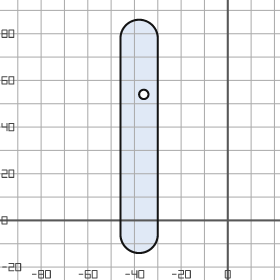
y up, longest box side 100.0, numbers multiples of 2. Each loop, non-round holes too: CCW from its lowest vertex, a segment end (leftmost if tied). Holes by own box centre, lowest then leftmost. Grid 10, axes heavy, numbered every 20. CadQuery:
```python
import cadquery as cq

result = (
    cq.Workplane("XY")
    .moveTo(-46.0, -6.0)
    .threePointArc((-38.0, -14.0), (-30.0, -6.0))
    .lineTo(-30.0, 78.0)
    .threePointArc((-38.0, 86.0), (-46.0, 78.0))
    .close()
    .moveTo(-36.0, 54.0)
    .circle(2.0)
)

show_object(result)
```